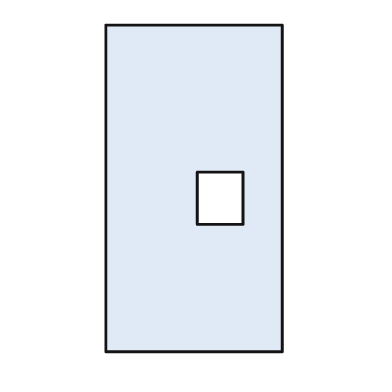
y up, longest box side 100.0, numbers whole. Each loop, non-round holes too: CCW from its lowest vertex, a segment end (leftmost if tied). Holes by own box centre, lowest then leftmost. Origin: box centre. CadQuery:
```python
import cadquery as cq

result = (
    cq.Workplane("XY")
    .moveTo(-27.0, -50.0)
    .lineTo(27.0, -50.0)
    .lineTo(27.0, 50.0)
    .lineTo(-27.0, 50.0)
    .close()
    .moveTo(1.0, -11.0)
    .lineTo(15.0, -11.0)
    .lineTo(15.0, 5.0)
    .lineTo(1.0, 5.0)
    .close()
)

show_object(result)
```